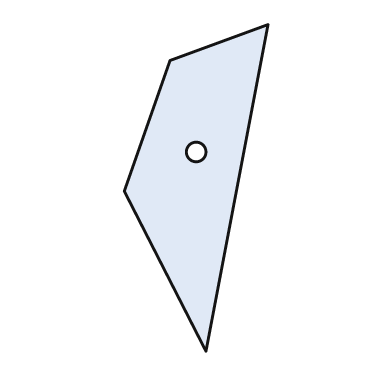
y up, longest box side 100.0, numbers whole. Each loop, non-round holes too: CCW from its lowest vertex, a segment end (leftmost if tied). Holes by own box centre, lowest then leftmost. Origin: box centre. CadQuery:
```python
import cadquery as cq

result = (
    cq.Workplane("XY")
    .moveTo(3.0, -50.0)
    .lineTo(22.0, 50.0)
    .lineTo(-8.0, 39.0)
    .lineTo(-22.0, -1.0)
    .close()
    .moveTo(0.0, 11.0)
    .circle(3.0)
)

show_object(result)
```